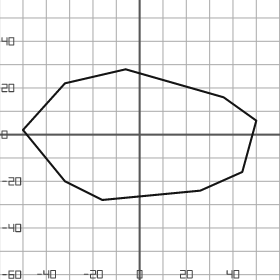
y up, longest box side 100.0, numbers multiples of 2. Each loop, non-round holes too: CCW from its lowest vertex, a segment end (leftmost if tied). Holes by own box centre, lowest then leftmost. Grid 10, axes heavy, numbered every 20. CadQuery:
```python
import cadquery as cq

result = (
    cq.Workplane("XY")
    .moveTo(-16.0, -28.0)
    .lineTo(26.0, -24.0)
    .lineTo(44.0, -16.0)
    .lineTo(50.0, 6.0)
    .lineTo(36.0, 16.0)
    .lineTo(-6.0, 28.0)
    .lineTo(-32.0, 22.0)
    .lineTo(-50.0, 2.0)
    .lineTo(-32.0, -20.0)
    .close()
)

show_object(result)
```